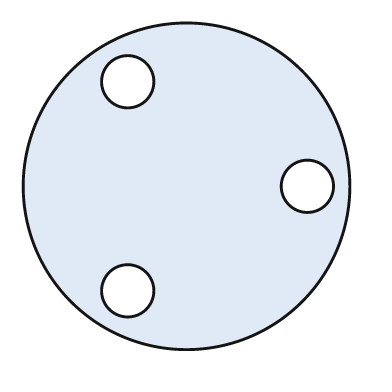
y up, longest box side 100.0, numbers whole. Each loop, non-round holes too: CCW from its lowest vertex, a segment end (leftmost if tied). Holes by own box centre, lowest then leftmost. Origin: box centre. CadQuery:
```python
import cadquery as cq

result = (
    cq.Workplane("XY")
    .moveTo(0.0, 0.0)
    .circle(50.0)
    .moveTo(-18.0, -32.0)
    .circle(8.0)
    .moveTo(37.0, 0.0)
    .circle(8.0)
    .moveTo(-18.0, 32.0)
    .circle(8.0)
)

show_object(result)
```